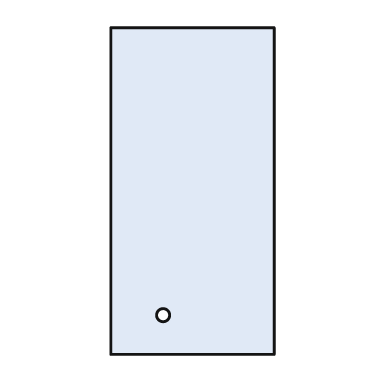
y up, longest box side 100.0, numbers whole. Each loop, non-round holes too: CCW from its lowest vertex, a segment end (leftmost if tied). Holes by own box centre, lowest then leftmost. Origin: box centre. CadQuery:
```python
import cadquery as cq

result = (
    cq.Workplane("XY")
    .moveTo(-25.0, -50.0)
    .lineTo(25.0, -50.0)
    .lineTo(25.0, 50.0)
    .lineTo(-25.0, 50.0)
    .close()
    .moveTo(-9.0, -38.0)
    .circle(2.0)
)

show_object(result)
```